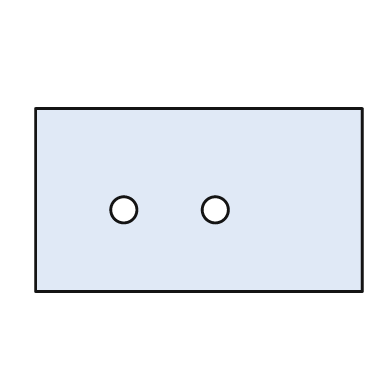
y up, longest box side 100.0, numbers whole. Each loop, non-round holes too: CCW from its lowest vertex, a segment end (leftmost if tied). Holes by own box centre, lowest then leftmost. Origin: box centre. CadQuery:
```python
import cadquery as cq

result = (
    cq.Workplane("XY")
    .moveTo(-50.0, -28.0)
    .lineTo(50.0, -28.0)
    .lineTo(50.0, 28.0)
    .lineTo(-50.0, 28.0)
    .close()
    .moveTo(-23.0, -3.0)
    .circle(4.0)
    .moveTo(5.0, -3.0)
    .circle(4.0)
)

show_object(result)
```